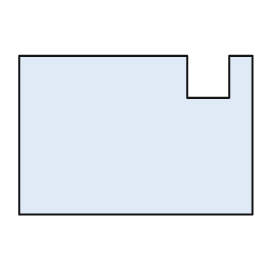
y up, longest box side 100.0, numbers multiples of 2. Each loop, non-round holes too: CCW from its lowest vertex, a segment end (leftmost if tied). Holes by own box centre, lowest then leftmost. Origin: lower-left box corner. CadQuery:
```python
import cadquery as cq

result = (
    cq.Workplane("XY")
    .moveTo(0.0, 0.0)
    .lineTo(100.0, 0.0)
    .lineTo(100.0, 68.0)
    .lineTo(90.0, 68.0)
    .lineTo(90.0, 50.0)
    .lineTo(72.0, 50.0)
    .lineTo(72.0, 68.0)
    .lineTo(0.0, 68.0)
    .close()
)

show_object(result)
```